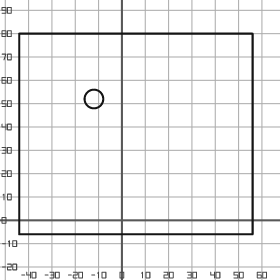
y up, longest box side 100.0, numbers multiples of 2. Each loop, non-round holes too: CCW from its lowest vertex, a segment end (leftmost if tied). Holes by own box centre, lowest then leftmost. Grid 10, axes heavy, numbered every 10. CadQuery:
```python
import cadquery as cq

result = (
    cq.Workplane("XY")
    .moveTo(-44.0, -6.0)
    .lineTo(56.0, -6.0)
    .lineTo(56.0, 80.0)
    .lineTo(-44.0, 80.0)
    .close()
    .moveTo(-12.0, 52.0)
    .circle(4.0)
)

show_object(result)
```